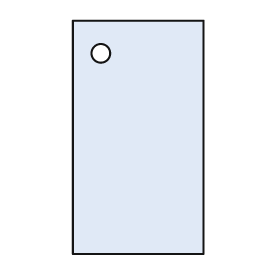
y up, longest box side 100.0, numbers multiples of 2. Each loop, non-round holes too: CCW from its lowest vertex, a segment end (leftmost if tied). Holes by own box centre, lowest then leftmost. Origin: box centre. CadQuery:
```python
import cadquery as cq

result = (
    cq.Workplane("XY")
    .moveTo(-28.0, -50.0)
    .lineTo(28.0, -50.0)
    .lineTo(28.0, 50.0)
    .lineTo(-28.0, 50.0)
    .close()
    .moveTo(-16.0, 36.0)
    .circle(4.0)
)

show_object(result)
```